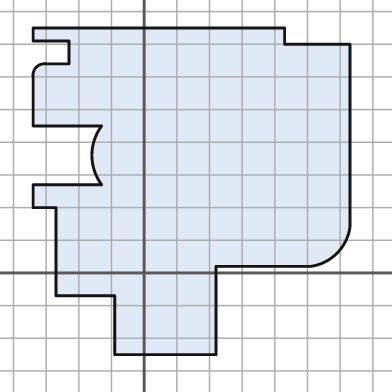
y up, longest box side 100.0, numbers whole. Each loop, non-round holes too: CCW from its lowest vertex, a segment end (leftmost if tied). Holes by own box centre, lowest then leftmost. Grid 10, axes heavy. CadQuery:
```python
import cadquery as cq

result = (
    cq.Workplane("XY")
    .moveTo(-9.0, -25.0)
    .lineTo(22.0, -25.0)
    .lineTo(22.0, 2.0)
    .lineTo(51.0, 2.0)
    .threePointArc((59.0, 6.0), (63.0, 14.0))
    .lineTo(63.0, 70.0)
    .lineTo(43.0, 70.0)
    .lineTo(43.0, 75.0)
    .lineTo(-34.0, 75.0)
    .lineTo(-34.0, 71.0)
    .lineTo(-23.0, 71.0)
    .lineTo(-23.0, 64.0)
    .lineTo(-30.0, 64.0)
    .threePointArc((-33.0, 63.0), (-34.0, 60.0))
    .lineTo(-34.0, 45.0)
    .lineTo(-13.0, 45.0)
    .threePointArc((-16.0, 36.0), (-13.0, 27.0))
    .lineTo(-34.0, 27.0)
    .lineTo(-34.0, 20.0)
    .lineTo(-27.0, 20.0)
    .lineTo(-27.0, -7.0)
    .lineTo(-9.0, -7.0)
    .close()
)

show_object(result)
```